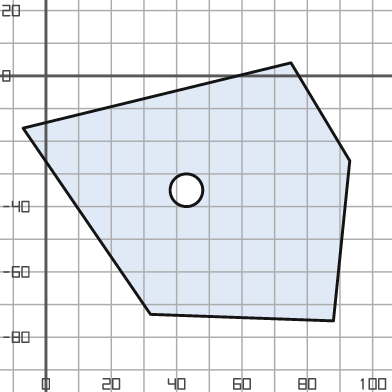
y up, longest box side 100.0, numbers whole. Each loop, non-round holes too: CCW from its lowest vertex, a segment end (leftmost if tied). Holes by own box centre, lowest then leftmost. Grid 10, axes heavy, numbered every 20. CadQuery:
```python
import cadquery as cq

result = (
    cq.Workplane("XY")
    .moveTo(88.0, -75.0)
    .lineTo(93.0, -26.0)
    .lineTo(75.0, 4.0)
    .lineTo(-7.0, -16.0)
    .lineTo(32.0, -73.0)
    .close()
    .moveTo(43.0, -35.0)
    .circle(5.0)
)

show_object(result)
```